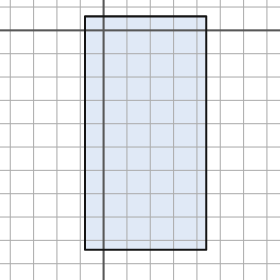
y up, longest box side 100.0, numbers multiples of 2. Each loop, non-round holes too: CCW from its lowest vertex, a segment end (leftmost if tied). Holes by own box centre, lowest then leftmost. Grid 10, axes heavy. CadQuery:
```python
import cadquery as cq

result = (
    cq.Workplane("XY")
    .moveTo(-8.0, -94.0)
    .lineTo(44.0, -94.0)
    .lineTo(44.0, 6.0)
    .lineTo(-8.0, 6.0)
    .close()
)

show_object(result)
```